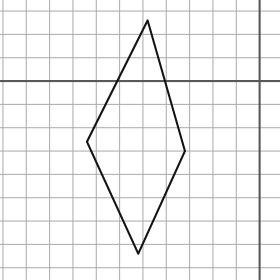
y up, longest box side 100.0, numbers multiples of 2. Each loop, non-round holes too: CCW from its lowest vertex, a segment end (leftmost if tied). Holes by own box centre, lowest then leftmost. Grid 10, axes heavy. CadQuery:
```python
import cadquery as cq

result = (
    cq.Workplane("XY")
    .moveTo(-52.0, -74.0)
    .lineTo(-32.0, -30.0)
    .lineTo(-48.0, 26.0)
    .lineTo(-74.0, -26.0)
    .close()
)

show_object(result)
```